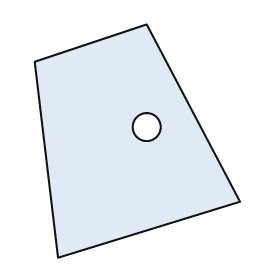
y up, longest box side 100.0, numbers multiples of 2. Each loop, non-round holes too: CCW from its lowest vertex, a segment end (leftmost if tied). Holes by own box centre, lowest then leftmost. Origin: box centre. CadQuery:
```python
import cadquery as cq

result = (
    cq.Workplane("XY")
    .moveTo(-34.0, -50.0)
    .lineTo(44.0, -26.0)
    .lineTo(4.0, 50.0)
    .lineTo(-44.0, 34.0)
    .close()
    .moveTo(4.0, 6.0)
    .circle(6.0)
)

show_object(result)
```